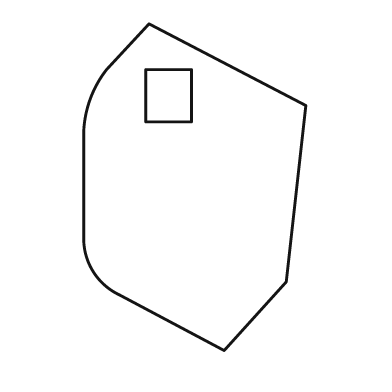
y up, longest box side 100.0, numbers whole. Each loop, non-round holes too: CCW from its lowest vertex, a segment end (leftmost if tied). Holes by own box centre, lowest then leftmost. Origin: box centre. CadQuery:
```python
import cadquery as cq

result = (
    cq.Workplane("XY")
    .moveTo(9.0, -50.0)
    .lineTo(28.0, -29.0)
    .lineTo(34.0, 25.0)
    .lineTo(-14.0, 50.0)
    .lineTo(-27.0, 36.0)
    .threePointArc((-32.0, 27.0), (-34.0, 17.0))
    .lineTo(-34.0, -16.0)
    .threePointArc((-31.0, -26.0), (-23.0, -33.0))
    .close()
    .moveTo(-15.0, 20.0)
    .lineTo(-1.0, 20.0)
    .lineTo(-1.0, 36.0)
    .lineTo(-15.0, 36.0)
    .close()
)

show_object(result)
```